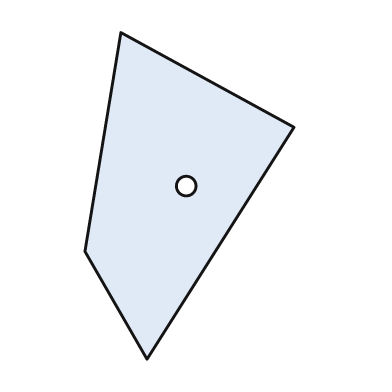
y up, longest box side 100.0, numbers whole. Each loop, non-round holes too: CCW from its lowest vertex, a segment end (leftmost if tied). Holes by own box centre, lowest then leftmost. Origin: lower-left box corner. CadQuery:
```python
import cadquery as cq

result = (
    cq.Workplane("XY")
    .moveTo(19.0, 0.0)
    .lineTo(64.0, 71.0)
    .lineTo(11.0, 100.0)
    .lineTo(0.0, 33.0)
    .close()
    .moveTo(31.0, 53.0)
    .circle(3.0)
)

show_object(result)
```